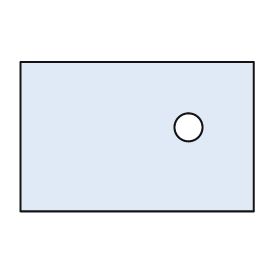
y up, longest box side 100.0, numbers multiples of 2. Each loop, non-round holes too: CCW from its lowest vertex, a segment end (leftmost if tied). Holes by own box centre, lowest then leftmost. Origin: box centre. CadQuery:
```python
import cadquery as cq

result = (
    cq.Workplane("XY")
    .moveTo(-50.0, -32.0)
    .lineTo(50.0, -32.0)
    .lineTo(50.0, 32.0)
    .lineTo(-50.0, 32.0)
    .close()
    .moveTo(22.0, 4.0)
    .circle(6.0)
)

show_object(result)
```